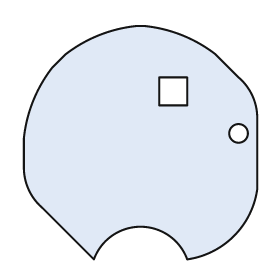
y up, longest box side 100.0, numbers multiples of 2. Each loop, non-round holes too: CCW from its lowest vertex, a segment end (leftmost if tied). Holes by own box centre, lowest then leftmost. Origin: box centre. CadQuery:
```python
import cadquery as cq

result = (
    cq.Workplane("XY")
    .moveTo(-20.0, -50.0)
    .threePointArc((0.0, -36.0), (20.0, -50.0))
    .threePointArc((40.0, -40.0), (50.0, -20.0))
    .lineTo(50.0, 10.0)
    .threePointArc((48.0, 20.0), (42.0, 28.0))
    .lineTo(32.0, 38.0)
    .threePointArc((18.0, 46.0), (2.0, 50.0))
    .lineTo(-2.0, 50.0)
    .threePointArc((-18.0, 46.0), (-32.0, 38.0))
    .lineTo(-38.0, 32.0)
    .threePointArc((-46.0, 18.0), (-50.0, 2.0))
    .lineTo(-50.0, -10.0)
    .threePointArc((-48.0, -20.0), (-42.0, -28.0))
    .close()
    .moveTo(42.0, 4.0)
    .circle(4.0)
    .moveTo(8.0, 16.0)
    .lineTo(20.0, 16.0)
    .lineTo(20.0, 28.0)
    .lineTo(8.0, 28.0)
    .close()
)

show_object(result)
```